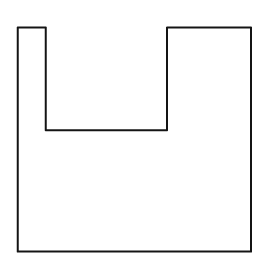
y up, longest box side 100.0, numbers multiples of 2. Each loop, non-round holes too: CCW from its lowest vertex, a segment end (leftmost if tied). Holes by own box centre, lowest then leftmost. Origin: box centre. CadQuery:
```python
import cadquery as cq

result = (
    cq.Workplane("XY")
    .moveTo(-50.0, -48.0)
    .lineTo(50.0, -48.0)
    .lineTo(50.0, 48.0)
    .lineTo(14.0, 48.0)
    .lineTo(14.0, 4.0)
    .lineTo(-38.0, 4.0)
    .lineTo(-38.0, 48.0)
    .lineTo(-50.0, 48.0)
    .close()
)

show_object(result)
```